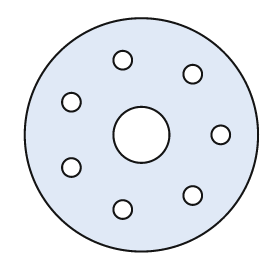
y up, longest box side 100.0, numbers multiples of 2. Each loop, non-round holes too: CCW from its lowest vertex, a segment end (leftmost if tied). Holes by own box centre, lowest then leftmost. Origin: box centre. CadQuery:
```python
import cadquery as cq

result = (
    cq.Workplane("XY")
    .moveTo(0.0, 0.0)
    .circle(50.0)
    .moveTo(-8.0, -32.0)
    .circle(4.0)
    .moveTo(22.0, -26.0)
    .circle(4.0)
    .moveTo(-30.0, -14.0)
    .circle(4.0)
    .moveTo(0.0, 0.0)
    .circle(12.0)
    .moveTo(34.0, 0.0)
    .circle(4.0)
    .moveTo(-30.0, 14.0)
    .circle(4.0)
    .moveTo(22.0, 26.0)
    .circle(4.0)
    .moveTo(-8.0, 32.0)
    .circle(4.0)
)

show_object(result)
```